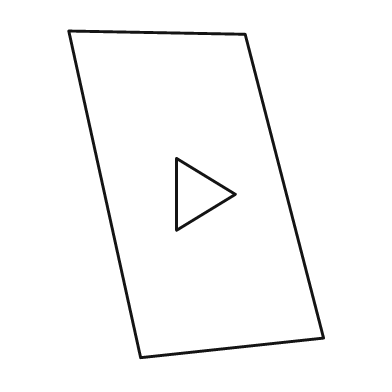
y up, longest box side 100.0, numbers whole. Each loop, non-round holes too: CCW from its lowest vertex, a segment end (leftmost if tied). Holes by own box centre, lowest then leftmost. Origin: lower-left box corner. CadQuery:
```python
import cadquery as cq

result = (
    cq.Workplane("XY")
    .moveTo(22.0, 0.0)
    .lineTo(78.0, 6.0)
    .lineTo(54.0, 99.0)
    .lineTo(0.0, 100.0)
    .close()
    .moveTo(33.0, 39.0)
    .lineTo(51.0, 50.0)
    .lineTo(33.0, 61.0)
    .close()
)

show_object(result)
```